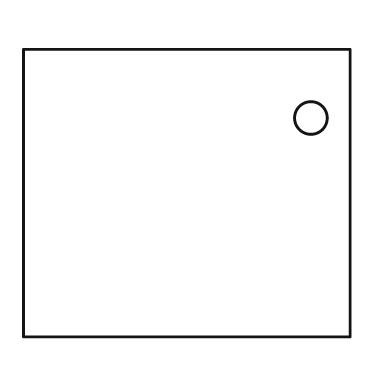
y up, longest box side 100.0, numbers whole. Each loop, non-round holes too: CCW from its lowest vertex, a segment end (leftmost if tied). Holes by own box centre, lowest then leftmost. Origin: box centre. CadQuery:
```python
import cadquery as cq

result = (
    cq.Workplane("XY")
    .moveTo(-50.0, -44.0)
    .lineTo(50.0, -44.0)
    .lineTo(50.0, 44.0)
    .lineTo(-50.0, 44.0)
    .close()
    .moveTo(38.0, 23.0)
    .circle(5.0)
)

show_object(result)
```